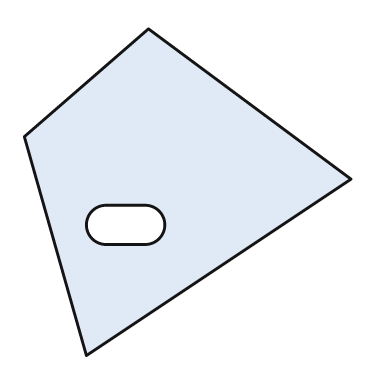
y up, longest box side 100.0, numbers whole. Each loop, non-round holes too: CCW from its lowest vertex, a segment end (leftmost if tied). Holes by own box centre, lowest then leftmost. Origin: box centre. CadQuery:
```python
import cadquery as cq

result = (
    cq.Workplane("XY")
    .moveTo(-31.0, -50.0)
    .lineTo(50.0, 4.0)
    .lineTo(-12.0, 50.0)
    .lineTo(-50.0, 17.0)
    .close()
    .moveTo(-25.0, -16.0)
    .lineTo(-13.0, -16.0)
    .threePointArc((-7.0, -10.0), (-13.0, -4.0))
    .lineTo(-25.0, -4.0)
    .threePointArc((-31.0, -10.0), (-25.0, -16.0))
    .close()
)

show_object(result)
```